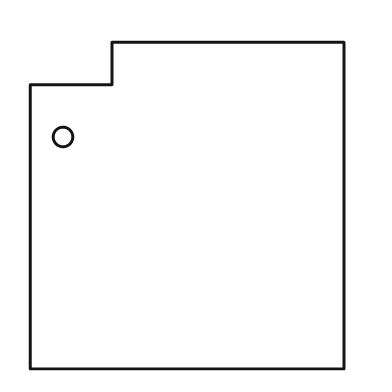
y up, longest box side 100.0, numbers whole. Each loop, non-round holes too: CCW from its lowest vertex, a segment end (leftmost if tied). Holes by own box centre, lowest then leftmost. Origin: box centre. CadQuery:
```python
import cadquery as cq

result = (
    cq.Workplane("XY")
    .moveTo(-48.0, -50.0)
    .lineTo(48.0, -50.0)
    .lineTo(48.0, 50.0)
    .lineTo(-23.0, 50.0)
    .lineTo(-23.0, 37.0)
    .lineTo(-48.0, 37.0)
    .close()
    .moveTo(-38.0, 21.0)
    .circle(3.0)
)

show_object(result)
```